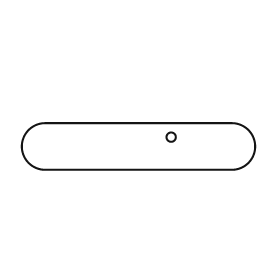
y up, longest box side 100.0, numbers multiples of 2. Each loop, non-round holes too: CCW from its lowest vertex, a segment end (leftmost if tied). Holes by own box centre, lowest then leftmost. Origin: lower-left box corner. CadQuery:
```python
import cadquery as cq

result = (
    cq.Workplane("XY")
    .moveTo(10.0, 0.0)
    .lineTo(90.0, 0.0)
    .threePointArc((100.0, 10.0), (90.0, 20.0))
    .lineTo(10.0, 20.0)
    .threePointArc((0.0, 10.0), (10.0, 0.0))
    .close()
    .moveTo(64.0, 14.0)
    .circle(2.0)
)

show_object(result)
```